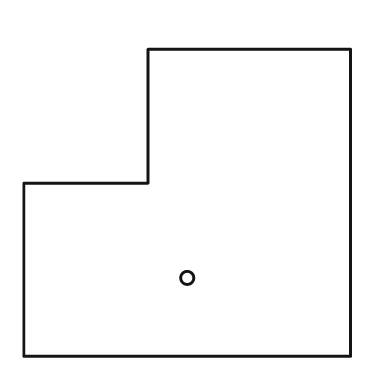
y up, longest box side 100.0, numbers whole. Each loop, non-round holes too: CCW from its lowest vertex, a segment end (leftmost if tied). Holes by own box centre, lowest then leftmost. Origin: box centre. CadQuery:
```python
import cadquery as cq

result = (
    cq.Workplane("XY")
    .moveTo(-50.0, -47.0)
    .lineTo(50.0, -47.0)
    .lineTo(50.0, 47.0)
    .lineTo(-12.0, 47.0)
    .lineTo(-12.0, 6.0)
    .lineTo(-50.0, 6.0)
    .close()
    .moveTo(0.0, -23.0)
    .circle(2.0)
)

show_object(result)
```